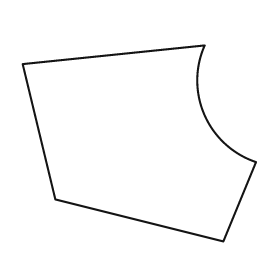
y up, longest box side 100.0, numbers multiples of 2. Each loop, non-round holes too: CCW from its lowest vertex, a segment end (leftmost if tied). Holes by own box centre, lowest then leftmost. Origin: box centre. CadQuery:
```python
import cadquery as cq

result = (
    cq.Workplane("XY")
    .moveTo(36.0, -42.0)
    .lineTo(50.0, -8.0)
    .threePointArc((28.0, 12.0), (28.0, 42.0))
    .lineTo(-50.0, 34.0)
    .lineTo(-36.0, -24.0)
    .close()
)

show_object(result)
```